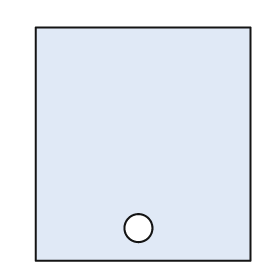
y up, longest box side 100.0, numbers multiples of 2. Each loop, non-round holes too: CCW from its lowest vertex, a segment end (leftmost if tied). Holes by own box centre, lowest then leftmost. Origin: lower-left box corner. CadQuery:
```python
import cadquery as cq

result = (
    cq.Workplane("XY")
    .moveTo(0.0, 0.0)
    .lineTo(92.0, 0.0)
    .lineTo(92.0, 100.0)
    .lineTo(0.0, 100.0)
    .close()
    .moveTo(44.0, 14.0)
    .circle(6.0)
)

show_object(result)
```